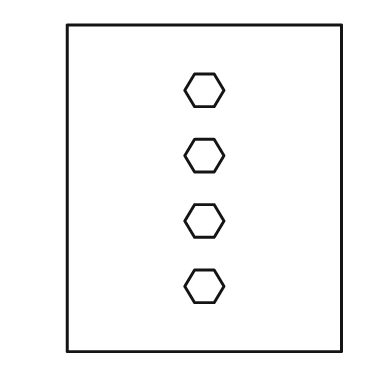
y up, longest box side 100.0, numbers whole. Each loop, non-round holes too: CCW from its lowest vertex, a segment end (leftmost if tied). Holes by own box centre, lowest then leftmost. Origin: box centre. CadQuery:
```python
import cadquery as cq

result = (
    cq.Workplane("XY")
    .moveTo(-42.0, -50.0)
    .lineTo(42.0, -50.0)
    .lineTo(42.0, 50.0)
    .lineTo(-42.0, 50.0)
    .close()
    .moveTo(-3.0, -35.0)
    .lineTo(3.0, -35.0)
    .lineTo(6.0, -30.0)
    .lineTo(3.0, -25.0)
    .lineTo(-3.0, -25.0)
    .lineTo(-6.0, -30.0)
    .close()
    .moveTo(-3.0, -15.0)
    .lineTo(3.0, -15.0)
    .lineTo(6.0, -10.0)
    .lineTo(3.0, -5.0)
    .lineTo(-3.0, -5.0)
    .lineTo(-6.0, -10.0)
    .close()
    .moveTo(-3.0, 5.0)
    .lineTo(3.0, 5.0)
    .lineTo(6.0, 10.0)
    .lineTo(3.0, 15.0)
    .lineTo(-3.0, 15.0)
    .lineTo(-6.0, 10.0)
    .close()
    .moveTo(-3.0, 25.0)
    .lineTo(3.0, 25.0)
    .lineTo(6.0, 30.0)
    .lineTo(3.0, 35.0)
    .lineTo(-3.0, 35.0)
    .lineTo(-6.0, 30.0)
    .close()
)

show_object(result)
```